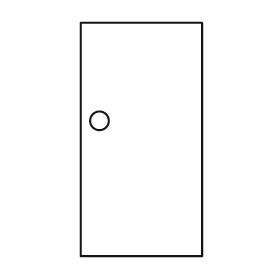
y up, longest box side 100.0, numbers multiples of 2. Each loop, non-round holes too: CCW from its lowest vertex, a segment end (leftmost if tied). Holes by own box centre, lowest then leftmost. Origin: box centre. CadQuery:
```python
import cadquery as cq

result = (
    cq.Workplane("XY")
    .moveTo(-26.0, -50.0)
    .lineTo(26.0, -50.0)
    .lineTo(26.0, 50.0)
    .lineTo(-26.0, 50.0)
    .close()
    .moveTo(-18.0, 8.0)
    .circle(4.0)
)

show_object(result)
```